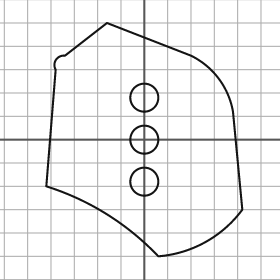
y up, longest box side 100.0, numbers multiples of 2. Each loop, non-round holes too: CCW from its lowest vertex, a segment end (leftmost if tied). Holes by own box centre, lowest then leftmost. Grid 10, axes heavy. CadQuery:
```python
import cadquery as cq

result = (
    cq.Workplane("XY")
    .moveTo(6.0, -50.0)
    .threePointArc((26.0, -44.0), (42.0, -30.0))
    .lineTo(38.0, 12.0)
    .threePointArc((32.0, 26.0), (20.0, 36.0))
    .lineTo(-16.0, 50.0)
    .lineTo(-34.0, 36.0)
    .threePointArc((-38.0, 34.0), (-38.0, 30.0))
    .lineTo(-42.0, -20.0)
    .threePointArc((-16.0, -32.0), (6.0, -50.0))
    .close()
    .moveTo(0.0, -18.0)
    .circle(6.0)
    .moveTo(0.0, 0.0)
    .circle(6.0)
    .moveTo(0.0, 18.0)
    .circle(6.0)
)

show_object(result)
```